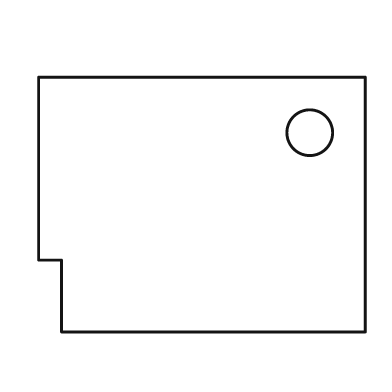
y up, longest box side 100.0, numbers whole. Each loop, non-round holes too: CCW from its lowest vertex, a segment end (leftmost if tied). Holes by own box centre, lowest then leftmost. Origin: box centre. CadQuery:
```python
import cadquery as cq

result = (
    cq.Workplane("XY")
    .moveTo(-43.0, -39.0)
    .lineTo(50.0, -39.0)
    .lineTo(50.0, 39.0)
    .lineTo(-50.0, 39.0)
    .lineTo(-50.0, -17.0)
    .lineTo(-43.0, -17.0)
    .close()
    .moveTo(33.0, 22.0)
    .circle(7.0)
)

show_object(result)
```